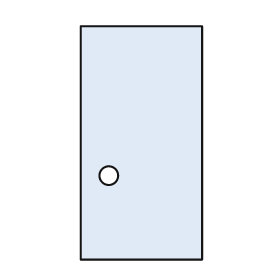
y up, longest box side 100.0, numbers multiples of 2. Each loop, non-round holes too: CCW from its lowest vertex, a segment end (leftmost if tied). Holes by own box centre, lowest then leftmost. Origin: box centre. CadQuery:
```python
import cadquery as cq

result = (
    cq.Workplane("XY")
    .moveTo(-26.0, -50.0)
    .lineTo(26.0, -50.0)
    .lineTo(26.0, 50.0)
    .lineTo(-26.0, 50.0)
    .close()
    .moveTo(-14.0, -14.0)
    .circle(4.0)
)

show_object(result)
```